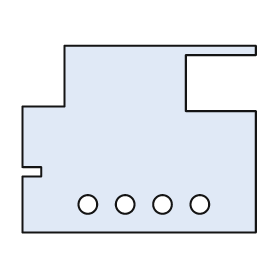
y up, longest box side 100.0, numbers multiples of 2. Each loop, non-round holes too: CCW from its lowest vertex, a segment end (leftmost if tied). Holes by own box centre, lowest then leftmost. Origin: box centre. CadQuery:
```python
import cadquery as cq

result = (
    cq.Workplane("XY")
    .moveTo(-50.0, -40.0)
    .lineTo(50.0, -40.0)
    .lineTo(50.0, 12.0)
    .lineTo(20.0, 12.0)
    .lineTo(20.0, 36.0)
    .lineTo(50.0, 36.0)
    .lineTo(50.0, 40.0)
    .lineTo(-32.0, 40.0)
    .lineTo(-32.0, 14.0)
    .lineTo(-50.0, 14.0)
    .lineTo(-50.0, -12.0)
    .lineTo(-42.0, -12.0)
    .lineTo(-42.0, -16.0)
    .lineTo(-50.0, -16.0)
    .close()
    .moveTo(-22.0, -28.0)
    .circle(4.0)
    .moveTo(-6.0, -28.0)
    .circle(4.0)
    .moveTo(10.0, -28.0)
    .circle(4.0)
    .moveTo(26.0, -28.0)
    .circle(4.0)
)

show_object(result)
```